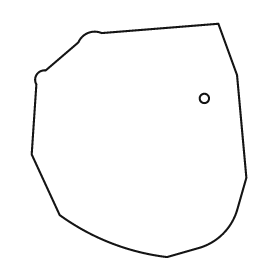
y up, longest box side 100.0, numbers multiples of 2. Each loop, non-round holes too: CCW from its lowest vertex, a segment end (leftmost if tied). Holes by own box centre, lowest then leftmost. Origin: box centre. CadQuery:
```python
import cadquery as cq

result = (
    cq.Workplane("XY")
    .moveTo(12.0, -50.0)
    .lineTo(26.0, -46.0)
    .threePointArc((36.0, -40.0), (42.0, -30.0))
    .lineTo(46.0, -16.0)
    .lineTo(42.0, 28.0)
    .lineTo(34.0, 50.0)
    .lineTo(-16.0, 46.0)
    .threePointArc((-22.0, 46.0), (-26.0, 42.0))
    .lineTo(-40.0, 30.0)
    .threePointArc((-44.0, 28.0), (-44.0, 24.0))
    .lineTo(-46.0, -6.0)
    .lineTo(-34.0, -32.0)
    .threePointArc((-12.0, -44.0), (12.0, -50.0))
    .close()
    .moveTo(28.0, 18.0)
    .circle(2.0)
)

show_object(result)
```